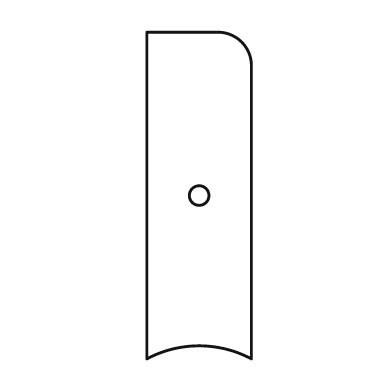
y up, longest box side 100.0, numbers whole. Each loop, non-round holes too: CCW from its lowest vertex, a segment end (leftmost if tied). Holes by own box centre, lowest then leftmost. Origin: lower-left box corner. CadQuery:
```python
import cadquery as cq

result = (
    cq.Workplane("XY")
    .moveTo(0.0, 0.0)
    .threePointArc((16.0, 4.0), (32.0, 0.0))
    .lineTo(32.0, 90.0)
    .threePointArc((29.0, 97.0), (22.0, 100.0))
    .lineTo(0.0, 100.0)
    .close()
    .moveTo(16.0, 50.0)
    .circle(3.0)
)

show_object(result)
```